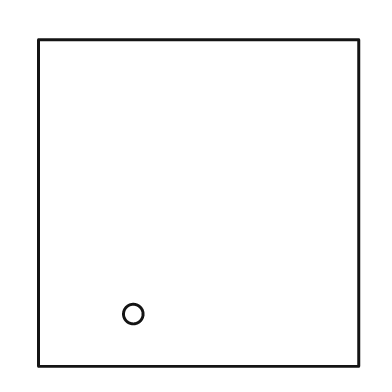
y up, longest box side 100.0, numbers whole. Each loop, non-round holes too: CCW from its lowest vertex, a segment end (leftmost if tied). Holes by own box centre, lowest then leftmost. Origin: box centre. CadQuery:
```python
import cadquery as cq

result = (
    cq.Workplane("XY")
    .moveTo(-49.0, -50.0)
    .lineTo(49.0, -50.0)
    .lineTo(49.0, 50.0)
    .lineTo(-49.0, 50.0)
    .close()
    .moveTo(-20.0, -34.0)
    .circle(3.0)
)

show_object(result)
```